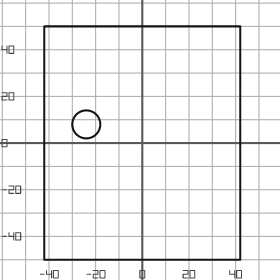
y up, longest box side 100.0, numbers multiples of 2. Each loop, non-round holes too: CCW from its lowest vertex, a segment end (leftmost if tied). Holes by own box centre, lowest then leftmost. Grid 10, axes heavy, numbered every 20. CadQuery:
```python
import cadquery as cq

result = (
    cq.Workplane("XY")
    .moveTo(-42.0, -50.0)
    .lineTo(42.0, -50.0)
    .lineTo(42.0, 50.0)
    .lineTo(-42.0, 50.0)
    .close()
    .moveTo(-24.0, 8.0)
    .circle(6.0)
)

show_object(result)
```